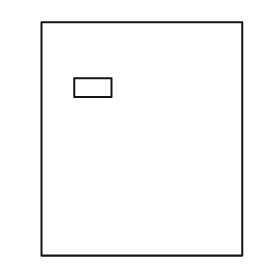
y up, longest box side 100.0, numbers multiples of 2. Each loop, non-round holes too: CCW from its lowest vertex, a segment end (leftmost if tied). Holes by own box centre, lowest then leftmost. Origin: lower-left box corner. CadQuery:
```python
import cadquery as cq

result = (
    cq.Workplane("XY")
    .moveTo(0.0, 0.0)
    .lineTo(86.0, 0.0)
    .lineTo(86.0, 100.0)
    .lineTo(0.0, 100.0)
    .close()
    .moveTo(14.0, 68.0)
    .lineTo(30.0, 68.0)
    .lineTo(30.0, 76.0)
    .lineTo(14.0, 76.0)
    .close()
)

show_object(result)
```